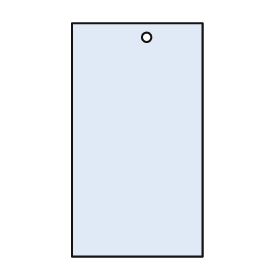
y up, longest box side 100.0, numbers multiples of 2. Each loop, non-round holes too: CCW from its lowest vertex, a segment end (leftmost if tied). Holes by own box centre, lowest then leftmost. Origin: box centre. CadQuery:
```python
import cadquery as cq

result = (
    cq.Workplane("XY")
    .moveTo(-28.0, -50.0)
    .lineTo(28.0, -50.0)
    .lineTo(28.0, 50.0)
    .lineTo(-28.0, 50.0)
    .close()
    .moveTo(4.0, 44.0)
    .circle(2.0)
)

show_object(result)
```